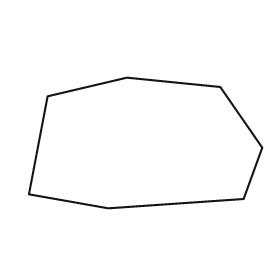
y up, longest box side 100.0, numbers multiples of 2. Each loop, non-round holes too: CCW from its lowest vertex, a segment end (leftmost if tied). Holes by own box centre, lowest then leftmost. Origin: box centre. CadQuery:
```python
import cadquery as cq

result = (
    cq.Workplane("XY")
    .moveTo(-16.0, -28.0)
    .lineTo(42.0, -24.0)
    .lineTo(50.0, -2.0)
    .lineTo(32.0, 24.0)
    .lineTo(-8.0, 28.0)
    .lineTo(-42.0, 20.0)
    .lineTo(-50.0, -22.0)
    .close()
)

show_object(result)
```